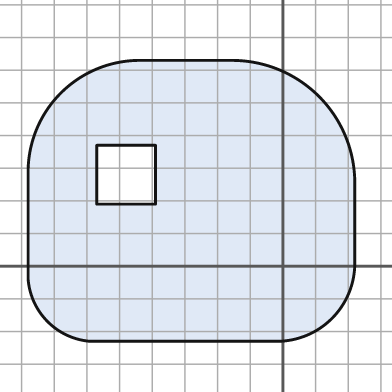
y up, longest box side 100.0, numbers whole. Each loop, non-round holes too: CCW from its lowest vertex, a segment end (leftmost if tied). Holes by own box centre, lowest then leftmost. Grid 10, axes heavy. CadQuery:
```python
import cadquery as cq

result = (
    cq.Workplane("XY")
    .moveTo(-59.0, -23.0)
    .lineTo(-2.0, -23.0)
    .threePointArc((15.0, -16.0), (22.0, 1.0))
    .lineTo(22.0, 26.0)
    .threePointArc((11.0, 52.0), (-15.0, 63.0))
    .lineTo(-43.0, 63.0)
    .threePointArc((-68.0, 53.0), (-78.0, 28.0))
    .lineTo(-78.0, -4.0)
    .threePointArc((-72.0, -17.0), (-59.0, -23.0))
    .close()
    .moveTo(-57.0, 19.0)
    .lineTo(-39.0, 19.0)
    .lineTo(-39.0, 37.0)
    .lineTo(-57.0, 37.0)
    .close()
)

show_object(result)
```